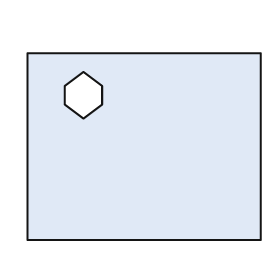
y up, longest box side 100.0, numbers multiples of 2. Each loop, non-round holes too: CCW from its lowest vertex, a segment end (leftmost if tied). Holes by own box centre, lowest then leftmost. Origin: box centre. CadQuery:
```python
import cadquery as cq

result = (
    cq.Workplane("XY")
    .moveTo(-50.0, -40.0)
    .lineTo(50.0, -40.0)
    .lineTo(50.0, 40.0)
    .lineTo(-50.0, 40.0)
    .close()
    .moveTo(-26.0, 12.0)
    .lineTo(-18.0, 18.0)
    .lineTo(-18.0, 26.0)
    .lineTo(-26.0, 32.0)
    .lineTo(-34.0, 26.0)
    .lineTo(-34.0, 18.0)
    .close()
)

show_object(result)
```